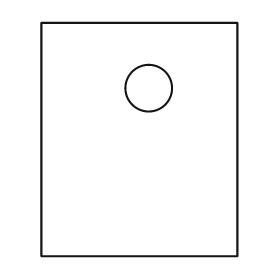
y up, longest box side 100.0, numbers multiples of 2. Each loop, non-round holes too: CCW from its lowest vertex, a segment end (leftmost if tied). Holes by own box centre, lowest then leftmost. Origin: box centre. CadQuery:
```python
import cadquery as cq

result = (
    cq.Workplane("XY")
    .moveTo(-42.0, -50.0)
    .lineTo(42.0, -50.0)
    .lineTo(42.0, 50.0)
    .lineTo(-42.0, 50.0)
    .close()
    .moveTo(4.0, 22.0)
    .circle(10.0)
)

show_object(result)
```